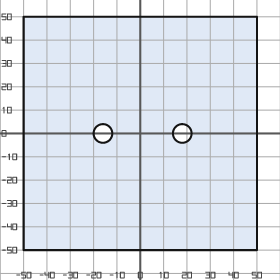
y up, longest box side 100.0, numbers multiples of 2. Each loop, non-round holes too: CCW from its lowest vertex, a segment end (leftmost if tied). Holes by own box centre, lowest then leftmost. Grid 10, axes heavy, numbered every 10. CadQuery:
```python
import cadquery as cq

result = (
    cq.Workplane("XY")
    .moveTo(-50.0, -50.0)
    .lineTo(50.0, -50.0)
    .lineTo(50.0, 50.0)
    .lineTo(-50.0, 50.0)
    .close()
    .moveTo(-16.0, 0.0)
    .circle(4.0)
    .moveTo(18.0, 0.0)
    .circle(4.0)
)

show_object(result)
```